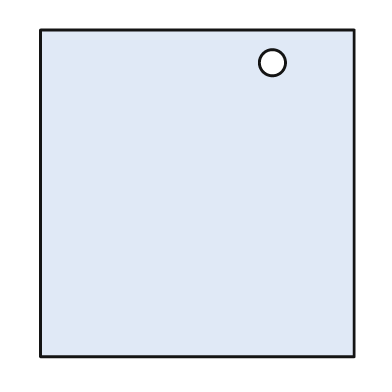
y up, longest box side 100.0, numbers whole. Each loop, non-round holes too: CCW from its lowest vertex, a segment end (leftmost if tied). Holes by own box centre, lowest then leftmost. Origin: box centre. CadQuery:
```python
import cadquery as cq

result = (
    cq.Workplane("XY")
    .moveTo(-48.0, -50.0)
    .lineTo(48.0, -50.0)
    .lineTo(48.0, 50.0)
    .lineTo(-48.0, 50.0)
    .close()
    .moveTo(23.0, 40.0)
    .circle(4.0)
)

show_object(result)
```